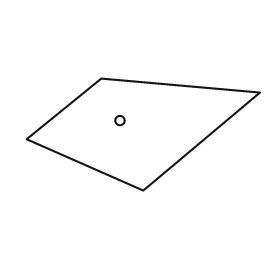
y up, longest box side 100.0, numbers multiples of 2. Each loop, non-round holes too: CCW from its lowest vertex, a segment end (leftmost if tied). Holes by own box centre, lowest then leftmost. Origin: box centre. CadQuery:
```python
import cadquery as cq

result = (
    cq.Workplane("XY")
    .moveTo(0.0, -24.0)
    .lineTo(50.0, 18.0)
    .lineTo(-18.0, 24.0)
    .lineTo(-50.0, -2.0)
    .close()
    .moveTo(-10.0, 6.0)
    .circle(2.0)
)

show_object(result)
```